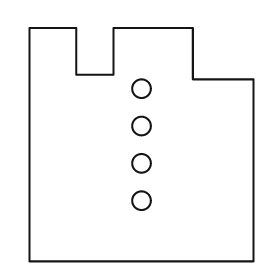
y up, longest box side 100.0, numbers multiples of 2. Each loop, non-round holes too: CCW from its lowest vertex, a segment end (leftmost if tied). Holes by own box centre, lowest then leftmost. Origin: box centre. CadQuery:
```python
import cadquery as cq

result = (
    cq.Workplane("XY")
    .moveTo(-48.0, -50.0)
    .lineTo(48.0, -50.0)
    .lineTo(48.0, 28.0)
    .lineTo(22.0, 28.0)
    .lineTo(22.0, 50.0)
    .lineTo(-12.0, 50.0)
    .lineTo(-12.0, 30.0)
    .lineTo(-28.0, 30.0)
    .lineTo(-28.0, 50.0)
    .lineTo(-48.0, 50.0)
    .close()
    .moveTo(0.0, -24.0)
    .circle(4.0)
    .moveTo(0.0, -8.0)
    .circle(4.0)
    .moveTo(0.0, 8.0)
    .circle(4.0)
    .moveTo(0.0, 24.0)
    .circle(4.0)
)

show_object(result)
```